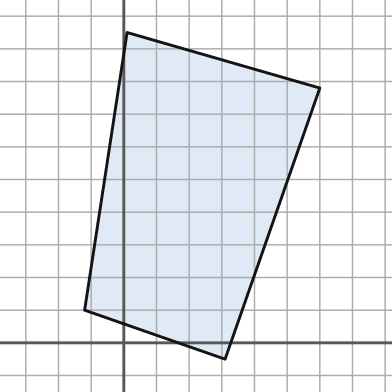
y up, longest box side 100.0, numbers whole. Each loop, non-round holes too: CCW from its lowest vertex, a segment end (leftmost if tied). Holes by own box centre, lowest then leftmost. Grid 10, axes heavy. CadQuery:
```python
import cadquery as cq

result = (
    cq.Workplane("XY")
    .moveTo(31.0, -5.0)
    .lineTo(60.0, 78.0)
    .lineTo(1.0, 95.0)
    .lineTo(-12.0, 10.0)
    .close()
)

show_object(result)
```